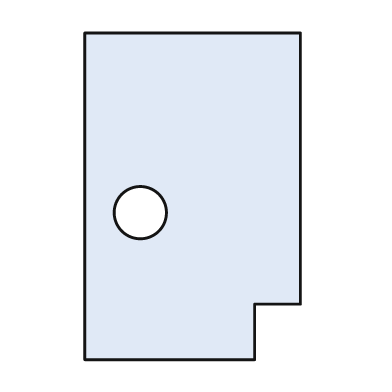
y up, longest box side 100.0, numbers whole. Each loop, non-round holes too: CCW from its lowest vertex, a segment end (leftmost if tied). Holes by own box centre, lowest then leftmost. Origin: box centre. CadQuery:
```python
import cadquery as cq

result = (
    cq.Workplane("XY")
    .moveTo(-33.0, -50.0)
    .lineTo(19.0, -50.0)
    .lineTo(19.0, -33.0)
    .lineTo(33.0, -33.0)
    .lineTo(33.0, 50.0)
    .lineTo(-33.0, 50.0)
    .close()
    .moveTo(-16.0, -5.0)
    .circle(8.0)
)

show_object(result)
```